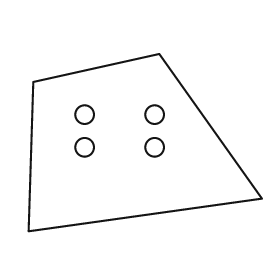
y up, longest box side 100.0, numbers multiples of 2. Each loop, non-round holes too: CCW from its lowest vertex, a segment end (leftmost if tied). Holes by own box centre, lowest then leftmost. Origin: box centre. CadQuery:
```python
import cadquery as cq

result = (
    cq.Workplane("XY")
    .moveTo(-50.0, -38.0)
    .lineTo(50.0, -24.0)
    .lineTo(6.0, 38.0)
    .lineTo(-48.0, 26.0)
    .close()
    .moveTo(-26.0, -2.0)
    .circle(4.0)
    .moveTo(4.0, -2.0)
    .circle(4.0)
    .moveTo(-26.0, 12.0)
    .circle(4.0)
    .moveTo(4.0, 12.0)
    .circle(4.0)
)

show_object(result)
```